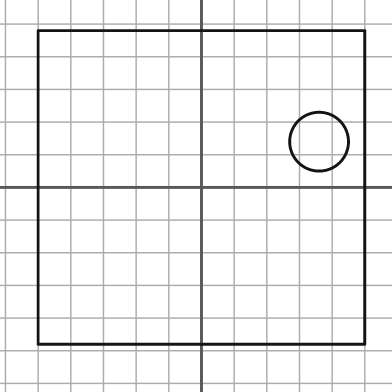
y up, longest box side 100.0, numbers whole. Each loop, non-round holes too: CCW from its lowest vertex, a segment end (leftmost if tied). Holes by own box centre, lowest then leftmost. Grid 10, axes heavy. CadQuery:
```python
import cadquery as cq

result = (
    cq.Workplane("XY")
    .moveTo(-50.0, -48.0)
    .lineTo(50.0, -48.0)
    .lineTo(50.0, 48.0)
    .lineTo(-50.0, 48.0)
    .close()
    .moveTo(36.0, 14.0)
    .circle(9.0)
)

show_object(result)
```